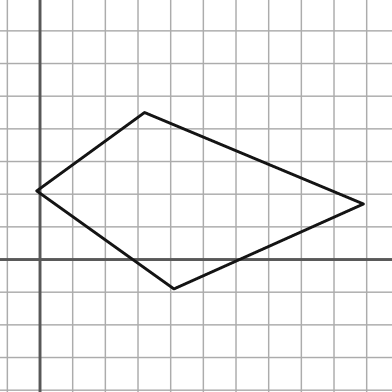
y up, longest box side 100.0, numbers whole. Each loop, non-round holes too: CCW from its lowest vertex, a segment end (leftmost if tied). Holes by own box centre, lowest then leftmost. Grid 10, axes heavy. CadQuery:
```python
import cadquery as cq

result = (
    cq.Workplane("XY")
    .moveTo(41.0, -9.0)
    .lineTo(99.0, 17.0)
    .lineTo(32.0, 45.0)
    .lineTo(-1.0, 21.0)
    .close()
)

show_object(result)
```